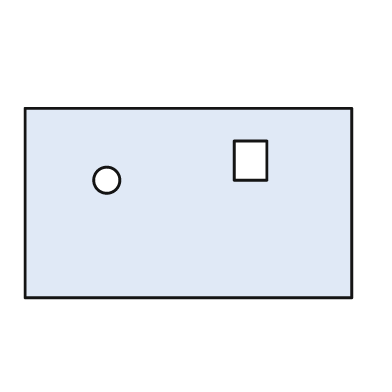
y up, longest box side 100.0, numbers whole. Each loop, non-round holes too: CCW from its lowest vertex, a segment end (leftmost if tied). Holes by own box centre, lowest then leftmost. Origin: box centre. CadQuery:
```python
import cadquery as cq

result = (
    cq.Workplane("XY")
    .moveTo(-50.0, -29.0)
    .lineTo(50.0, -29.0)
    .lineTo(50.0, 29.0)
    .lineTo(-50.0, 29.0)
    .close()
    .moveTo(-25.0, 7.0)
    .circle(4.0)
    .moveTo(14.0, 7.0)
    .lineTo(24.0, 7.0)
    .lineTo(24.0, 19.0)
    .lineTo(14.0, 19.0)
    .close()
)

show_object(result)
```